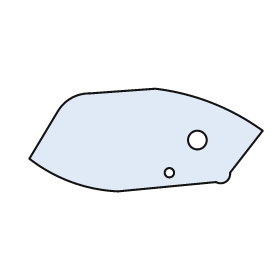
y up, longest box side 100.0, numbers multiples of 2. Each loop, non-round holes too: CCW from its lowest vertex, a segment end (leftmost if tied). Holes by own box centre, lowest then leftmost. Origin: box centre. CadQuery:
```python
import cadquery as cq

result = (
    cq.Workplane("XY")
    .moveTo(-12.0, -22.0)
    .lineTo(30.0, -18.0)
    .threePointArc((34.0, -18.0), (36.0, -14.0))
    .lineTo(50.0, 4.0)
    .threePointArc((28.0, 16.0), (4.0, 22.0))
    .lineTo(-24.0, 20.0)
    .threePointArc((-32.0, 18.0), (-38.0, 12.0))
    .lineTo(-50.0, -8.0)
    .threePointArc((-32.0, -18.0), (-12.0, -22.0))
    .close()
    .moveTo(10.0, -14.0)
    .circle(2.0)
    .moveTo(22.0, 0.0)
    .circle(4.0)
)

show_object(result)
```